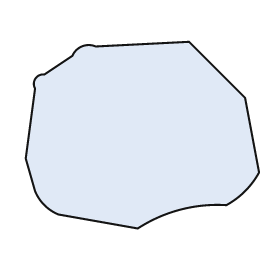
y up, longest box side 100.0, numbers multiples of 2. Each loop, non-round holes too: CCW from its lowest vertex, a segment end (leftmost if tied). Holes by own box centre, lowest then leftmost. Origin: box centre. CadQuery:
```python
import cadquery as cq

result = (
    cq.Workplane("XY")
    .moveTo(-2.0, -40.0)
    .threePointArc((16.0, -32.0), (36.0, -30.0))
    .threePointArc((44.0, -24.0), (50.0, -16.0))
    .lineTo(44.0, 16.0)
    .lineTo(20.0, 40.0)
    .lineTo(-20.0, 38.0)
    .threePointArc((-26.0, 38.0), (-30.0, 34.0))
    .lineTo(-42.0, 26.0)
    .threePointArc((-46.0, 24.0), (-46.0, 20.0))
    .lineTo(-50.0, -10.0)
    .lineTo(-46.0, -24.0)
    .threePointArc((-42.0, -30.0), (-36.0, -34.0))
    .close()
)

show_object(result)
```